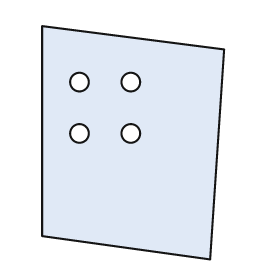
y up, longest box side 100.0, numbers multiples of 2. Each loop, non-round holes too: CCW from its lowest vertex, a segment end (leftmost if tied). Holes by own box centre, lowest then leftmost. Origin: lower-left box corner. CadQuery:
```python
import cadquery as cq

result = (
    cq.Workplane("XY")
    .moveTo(72.0, 0.0)
    .lineTo(78.0, 90.0)
    .lineTo(0.0, 100.0)
    .lineTo(0.0, 10.0)
    .close()
    .moveTo(16.0, 54.0)
    .circle(4.0)
    .moveTo(38.0, 54.0)
    .circle(4.0)
    .moveTo(16.0, 76.0)
    .circle(4.0)
    .moveTo(38.0, 76.0)
    .circle(4.0)
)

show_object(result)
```